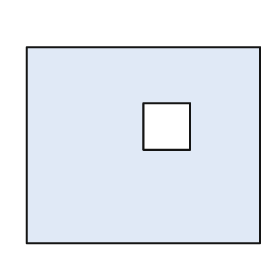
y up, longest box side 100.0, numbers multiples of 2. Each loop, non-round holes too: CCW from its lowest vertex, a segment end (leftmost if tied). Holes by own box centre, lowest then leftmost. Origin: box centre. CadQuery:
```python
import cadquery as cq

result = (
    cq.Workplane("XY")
    .moveTo(-50.0, -42.0)
    .lineTo(50.0, -42.0)
    .lineTo(50.0, 42.0)
    .lineTo(-50.0, 42.0)
    .close()
    .moveTo(0.0, -2.0)
    .lineTo(20.0, -2.0)
    .lineTo(20.0, 18.0)
    .lineTo(0.0, 18.0)
    .close()
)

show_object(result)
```